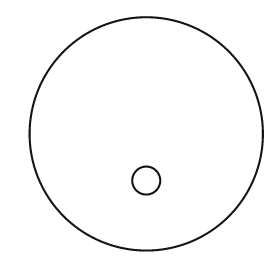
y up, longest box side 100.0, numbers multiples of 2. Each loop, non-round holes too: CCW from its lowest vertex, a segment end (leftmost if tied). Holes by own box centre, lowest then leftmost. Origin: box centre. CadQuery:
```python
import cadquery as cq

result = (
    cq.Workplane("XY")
    .moveTo(0.0, 0.0)
    .circle(50.0)
    .moveTo(0.0, -20.0)
    .circle(6.0)
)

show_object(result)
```